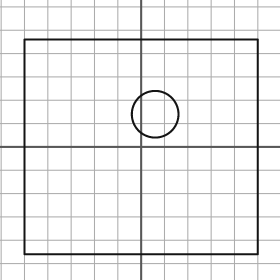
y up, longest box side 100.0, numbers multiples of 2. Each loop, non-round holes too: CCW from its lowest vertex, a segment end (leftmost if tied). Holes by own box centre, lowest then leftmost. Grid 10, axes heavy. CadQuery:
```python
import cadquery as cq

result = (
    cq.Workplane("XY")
    .moveTo(-50.0, -46.0)
    .lineTo(50.0, -46.0)
    .lineTo(50.0, 46.0)
    .lineTo(-50.0, 46.0)
    .close()
    .moveTo(6.0, 14.0)
    .circle(10.0)
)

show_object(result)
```